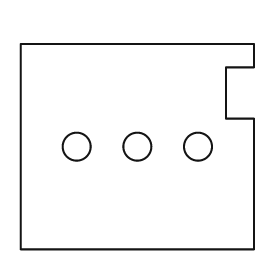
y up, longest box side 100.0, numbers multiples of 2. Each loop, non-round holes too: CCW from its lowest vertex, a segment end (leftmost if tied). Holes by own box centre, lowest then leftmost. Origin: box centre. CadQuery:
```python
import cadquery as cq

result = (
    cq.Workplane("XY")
    .moveTo(-50.0, -44.0)
    .lineTo(50.0, -44.0)
    .lineTo(50.0, 12.0)
    .lineTo(38.0, 12.0)
    .lineTo(38.0, 34.0)
    .lineTo(50.0, 34.0)
    .lineTo(50.0, 44.0)
    .lineTo(-50.0, 44.0)
    .close()
    .moveTo(-26.0, 0.0)
    .circle(6.0)
    .moveTo(0.0, 0.0)
    .circle(6.0)
    .moveTo(26.0, 0.0)
    .circle(6.0)
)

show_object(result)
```